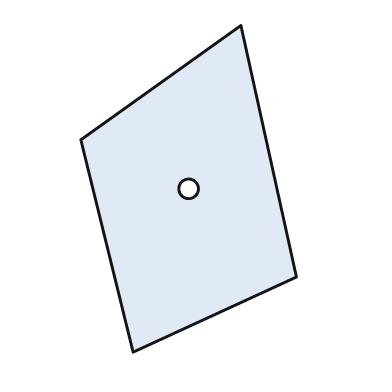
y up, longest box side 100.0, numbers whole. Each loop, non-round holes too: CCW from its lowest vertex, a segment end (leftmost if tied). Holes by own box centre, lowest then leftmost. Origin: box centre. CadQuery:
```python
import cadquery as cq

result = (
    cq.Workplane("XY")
    .moveTo(-17.0, -50.0)
    .lineTo(33.0, -27.0)
    .lineTo(16.0, 50.0)
    .lineTo(-33.0, 15.0)
    .close()
    .moveTo(0.0, 0.0)
    .circle(3.0)
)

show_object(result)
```